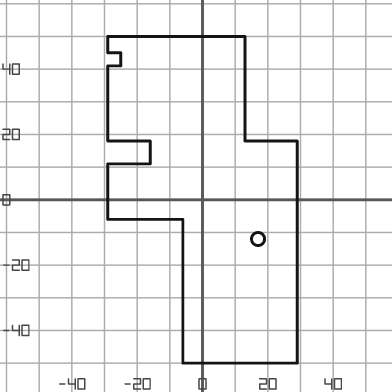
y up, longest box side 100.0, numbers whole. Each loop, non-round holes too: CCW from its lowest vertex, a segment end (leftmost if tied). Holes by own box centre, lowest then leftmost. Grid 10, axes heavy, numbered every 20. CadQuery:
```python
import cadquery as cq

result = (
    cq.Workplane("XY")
    .moveTo(-6.0, -50.0)
    .lineTo(29.0, -50.0)
    .lineTo(29.0, 18.0)
    .lineTo(13.0, 18.0)
    .lineTo(13.0, 50.0)
    .lineTo(-29.0, 50.0)
    .lineTo(-29.0, 45.0)
    .lineTo(-25.0, 45.0)
    .lineTo(-25.0, 41.0)
    .lineTo(-29.0, 41.0)
    .lineTo(-29.0, 18.0)
    .lineTo(-16.0, 18.0)
    .lineTo(-16.0, 11.0)
    .lineTo(-29.0, 11.0)
    .lineTo(-29.0, -6.0)
    .lineTo(-6.0, -6.0)
    .close()
    .moveTo(17.0, -12.0)
    .circle(2.0)
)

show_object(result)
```